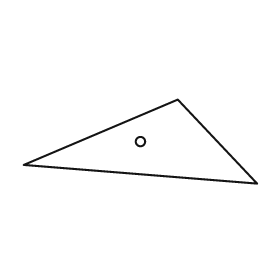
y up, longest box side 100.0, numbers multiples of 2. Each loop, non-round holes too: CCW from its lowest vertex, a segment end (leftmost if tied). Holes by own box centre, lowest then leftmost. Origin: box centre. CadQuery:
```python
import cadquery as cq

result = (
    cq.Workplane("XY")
    .moveTo(50.0, -18.0)
    .lineTo(16.0, 18.0)
    .lineTo(-50.0, -10.0)
    .close()
    .moveTo(0.0, 0.0)
    .circle(2.0)
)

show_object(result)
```